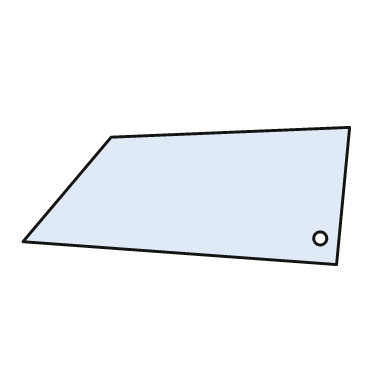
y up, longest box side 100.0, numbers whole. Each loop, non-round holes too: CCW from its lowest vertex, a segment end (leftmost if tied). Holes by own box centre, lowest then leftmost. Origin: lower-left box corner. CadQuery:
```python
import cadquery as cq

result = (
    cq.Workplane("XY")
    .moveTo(96.0, 0.0)
    .lineTo(100.0, 42.0)
    .lineTo(27.0, 39.0)
    .lineTo(0.0, 7.0)
    .close()
    .moveTo(91.0, 8.0)
    .circle(2.0)
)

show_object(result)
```